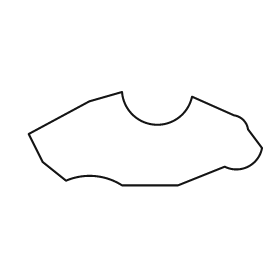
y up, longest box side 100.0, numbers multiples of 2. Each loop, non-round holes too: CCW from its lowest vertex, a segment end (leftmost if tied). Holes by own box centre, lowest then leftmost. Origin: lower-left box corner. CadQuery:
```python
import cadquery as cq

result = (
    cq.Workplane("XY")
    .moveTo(40.0, 0.0)
    .lineTo(64.0, 0.0)
    .lineTo(84.0, 8.0)
    .threePointArc((94.0, 8.0), (100.0, 16.0))
    .lineTo(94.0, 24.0)
    .threePointArc((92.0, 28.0), (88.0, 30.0))
    .lineTo(70.0, 38.0)
    .threePointArc((54.0, 26.0), (40.0, 40.0))
    .lineTo(26.0, 36.0)
    .lineTo(0.0, 22.0)
    .lineTo(6.0, 10.0)
    .lineTo(16.0, 2.0)
    .threePointArc((28.0, 4.0), (40.0, 0.0))
    .close()
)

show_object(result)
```